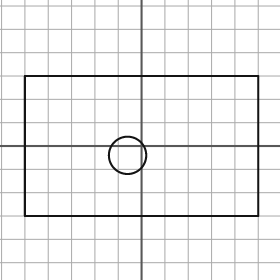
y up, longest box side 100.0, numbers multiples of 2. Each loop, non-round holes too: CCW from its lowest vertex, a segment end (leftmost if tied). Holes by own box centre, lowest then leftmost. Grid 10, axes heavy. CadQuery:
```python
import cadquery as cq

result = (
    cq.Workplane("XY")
    .moveTo(-50.0, -30.0)
    .lineTo(50.0, -30.0)
    .lineTo(50.0, 30.0)
    .lineTo(-50.0, 30.0)
    .close()
    .moveTo(-6.0, -4.0)
    .circle(8.0)
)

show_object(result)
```